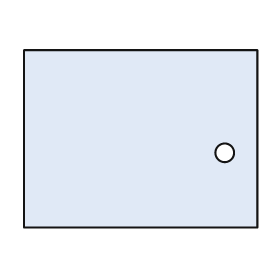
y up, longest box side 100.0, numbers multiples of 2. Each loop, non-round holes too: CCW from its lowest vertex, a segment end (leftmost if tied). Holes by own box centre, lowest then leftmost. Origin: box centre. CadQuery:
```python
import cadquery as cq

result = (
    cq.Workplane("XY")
    .moveTo(-50.0, -38.0)
    .lineTo(50.0, -38.0)
    .lineTo(50.0, 38.0)
    .lineTo(-50.0, 38.0)
    .close()
    .moveTo(36.0, -6.0)
    .circle(4.0)
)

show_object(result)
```